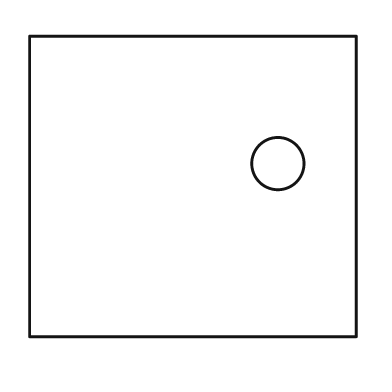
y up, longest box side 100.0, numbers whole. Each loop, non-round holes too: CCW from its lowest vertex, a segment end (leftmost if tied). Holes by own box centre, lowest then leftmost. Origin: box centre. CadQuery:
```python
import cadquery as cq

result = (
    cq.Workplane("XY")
    .moveTo(-50.0, -46.0)
    .lineTo(50.0, -46.0)
    .lineTo(50.0, 46.0)
    .lineTo(-50.0, 46.0)
    .close()
    .moveTo(26.0, 7.0)
    .circle(8.0)
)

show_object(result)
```